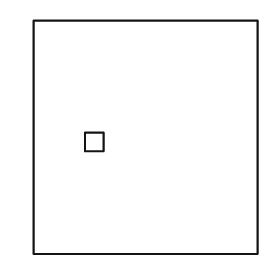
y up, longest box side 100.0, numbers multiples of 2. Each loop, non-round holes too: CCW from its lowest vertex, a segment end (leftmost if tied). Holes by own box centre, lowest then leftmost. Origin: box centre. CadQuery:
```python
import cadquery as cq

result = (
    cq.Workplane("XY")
    .moveTo(-48.0, -50.0)
    .lineTo(48.0, -50.0)
    .lineTo(48.0, 50.0)
    .lineTo(-48.0, 50.0)
    .close()
    .moveTo(-26.0, -6.0)
    .lineTo(-18.0, -6.0)
    .lineTo(-18.0, 2.0)
    .lineTo(-26.0, 2.0)
    .close()
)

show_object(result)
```